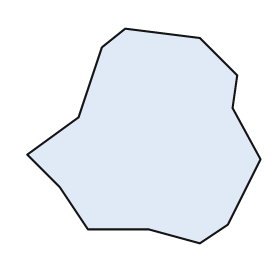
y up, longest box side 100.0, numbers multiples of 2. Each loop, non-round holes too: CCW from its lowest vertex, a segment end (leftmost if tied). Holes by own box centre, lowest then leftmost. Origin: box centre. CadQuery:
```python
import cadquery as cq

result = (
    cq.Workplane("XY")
    .moveTo(24.0, -46.0)
    .lineTo(36.0, -38.0)
    .lineTo(50.0, -10.0)
    .lineTo(38.0, 12.0)
    .lineTo(40.0, 26.0)
    .lineTo(24.0, 42.0)
    .lineTo(-8.0, 46.0)
    .lineTo(-18.0, 38.0)
    .lineTo(-28.0, 8.0)
    .lineTo(-50.0, -8.0)
    .lineTo(-36.0, -22.0)
    .lineTo(-24.0, -40.0)
    .lineTo(2.0, -40.0)
    .close()
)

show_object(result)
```